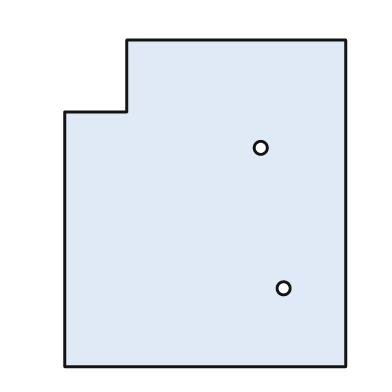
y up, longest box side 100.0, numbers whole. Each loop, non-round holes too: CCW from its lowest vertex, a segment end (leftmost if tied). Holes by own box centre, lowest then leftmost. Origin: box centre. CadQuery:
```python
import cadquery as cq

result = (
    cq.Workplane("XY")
    .moveTo(-43.0, -50.0)
    .lineTo(43.0, -50.0)
    .lineTo(43.0, 50.0)
    .lineTo(-24.0, 50.0)
    .lineTo(-24.0, 28.0)
    .lineTo(-43.0, 28.0)
    .close()
    .moveTo(24.0, -26.0)
    .circle(2.0)
    .moveTo(17.0, 17.0)
    .circle(2.0)
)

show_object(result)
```